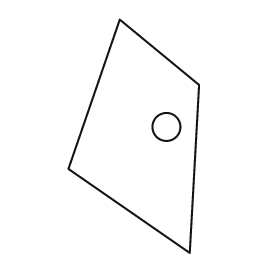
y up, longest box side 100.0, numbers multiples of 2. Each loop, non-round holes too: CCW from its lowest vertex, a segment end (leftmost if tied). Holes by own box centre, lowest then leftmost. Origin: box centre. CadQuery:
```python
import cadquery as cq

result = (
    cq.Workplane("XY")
    .moveTo(24.0, -50.0)
    .lineTo(28.0, 22.0)
    .lineTo(-6.0, 50.0)
    .lineTo(-28.0, -14.0)
    .close()
    .moveTo(14.0, 4.0)
    .circle(6.0)
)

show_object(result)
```